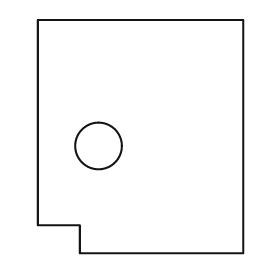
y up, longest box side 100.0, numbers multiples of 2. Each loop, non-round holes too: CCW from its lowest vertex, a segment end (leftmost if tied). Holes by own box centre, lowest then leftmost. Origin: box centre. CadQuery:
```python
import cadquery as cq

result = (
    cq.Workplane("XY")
    .moveTo(-26.0, -50.0)
    .lineTo(44.0, -50.0)
    .lineTo(44.0, 50.0)
    .lineTo(-44.0, 50.0)
    .lineTo(-44.0, -38.0)
    .lineTo(-26.0, -38.0)
    .close()
    .moveTo(-18.0, -4.0)
    .circle(10.0)
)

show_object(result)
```